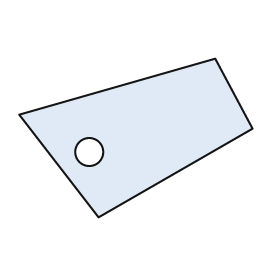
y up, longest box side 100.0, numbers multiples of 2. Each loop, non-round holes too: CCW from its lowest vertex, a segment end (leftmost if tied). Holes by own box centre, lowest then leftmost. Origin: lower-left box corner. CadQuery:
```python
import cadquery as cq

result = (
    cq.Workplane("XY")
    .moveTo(34.0, 0.0)
    .lineTo(100.0, 38.0)
    .lineTo(84.0, 68.0)
    .lineTo(0.0, 44.0)
    .close()
    .moveTo(30.0, 28.0)
    .circle(6.0)
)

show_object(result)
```